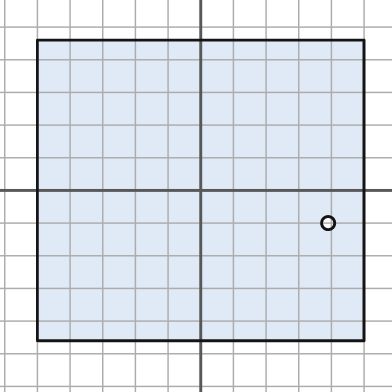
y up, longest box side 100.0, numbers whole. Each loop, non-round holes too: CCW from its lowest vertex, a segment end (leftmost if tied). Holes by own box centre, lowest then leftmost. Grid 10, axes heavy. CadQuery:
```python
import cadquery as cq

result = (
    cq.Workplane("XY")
    .moveTo(-50.0, -46.0)
    .lineTo(50.0, -46.0)
    .lineTo(50.0, 46.0)
    .lineTo(-50.0, 46.0)
    .close()
    .moveTo(39.0, -10.0)
    .circle(2.0)
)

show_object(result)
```